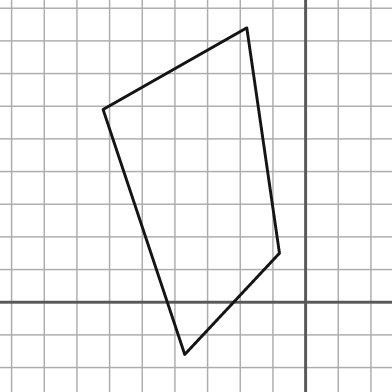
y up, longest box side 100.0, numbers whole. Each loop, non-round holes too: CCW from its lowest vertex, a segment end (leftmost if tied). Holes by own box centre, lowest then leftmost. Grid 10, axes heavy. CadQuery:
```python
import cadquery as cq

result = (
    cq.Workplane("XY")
    .moveTo(-37.0, -16.0)
    .lineTo(-8.0, 15.0)
    .lineTo(-18.0, 84.0)
    .lineTo(-62.0, 59.0)
    .close()
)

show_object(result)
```